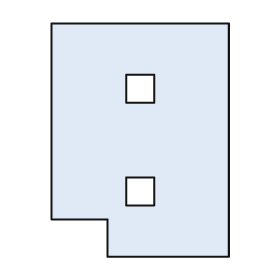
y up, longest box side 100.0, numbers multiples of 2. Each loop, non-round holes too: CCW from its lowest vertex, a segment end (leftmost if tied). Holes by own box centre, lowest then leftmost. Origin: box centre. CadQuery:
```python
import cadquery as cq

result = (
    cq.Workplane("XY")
    .moveTo(-14.0, -50.0)
    .lineTo(38.0, -50.0)
    .lineTo(38.0, 50.0)
    .lineTo(-38.0, 50.0)
    .lineTo(-38.0, -34.0)
    .lineTo(-14.0, -34.0)
    .close()
    .moveTo(-6.0, -28.0)
    .lineTo(6.0, -28.0)
    .lineTo(6.0, -16.0)
    .lineTo(-6.0, -16.0)
    .close()
    .moveTo(-6.0, 16.0)
    .lineTo(6.0, 16.0)
    .lineTo(6.0, 28.0)
    .lineTo(-6.0, 28.0)
    .close()
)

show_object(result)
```